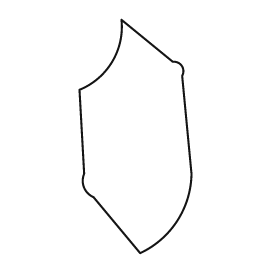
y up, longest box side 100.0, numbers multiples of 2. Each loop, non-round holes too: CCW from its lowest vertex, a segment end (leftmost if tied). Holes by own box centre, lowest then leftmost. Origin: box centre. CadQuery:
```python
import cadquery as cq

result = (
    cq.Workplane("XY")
    .moveTo(2.0, -50.0)
    .threePointArc((18.0, -36.0), (24.0, -16.0))
    .lineTo(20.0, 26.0)
    .threePointArc((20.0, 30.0), (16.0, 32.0))
    .lineTo(-6.0, 50.0)
    .threePointArc((-10.0, 32.0), (-24.0, 20.0))
    .lineTo(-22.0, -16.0)
    .threePointArc((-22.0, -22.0), (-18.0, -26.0))
    .close()
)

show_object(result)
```